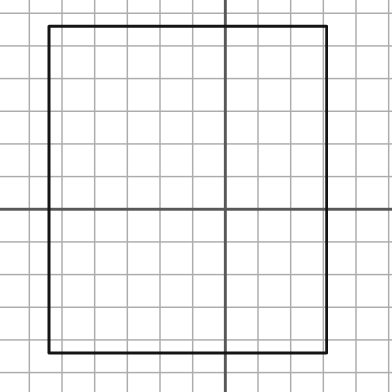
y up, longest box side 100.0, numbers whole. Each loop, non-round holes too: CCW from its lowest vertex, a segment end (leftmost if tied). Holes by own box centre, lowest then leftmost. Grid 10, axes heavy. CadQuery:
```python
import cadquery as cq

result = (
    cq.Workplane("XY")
    .moveTo(-54.0, -44.0)
    .lineTo(31.0, -44.0)
    .lineTo(31.0, 56.0)
    .lineTo(-54.0, 56.0)
    .close()
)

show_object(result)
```